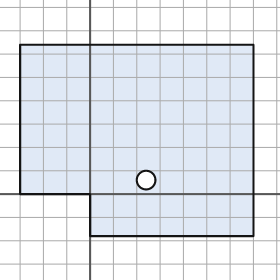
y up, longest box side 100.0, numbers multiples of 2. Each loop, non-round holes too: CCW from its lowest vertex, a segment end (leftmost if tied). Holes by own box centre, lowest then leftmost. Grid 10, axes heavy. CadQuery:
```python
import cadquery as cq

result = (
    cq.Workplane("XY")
    .moveTo(0.0, -18.0)
    .lineTo(70.0, -18.0)
    .lineTo(70.0, 64.0)
    .lineTo(-30.0, 64.0)
    .lineTo(-30.0, 0.0)
    .lineTo(0.0, 0.0)
    .close()
    .moveTo(24.0, 6.0)
    .circle(4.0)
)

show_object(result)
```